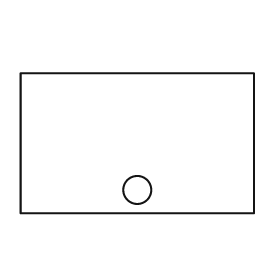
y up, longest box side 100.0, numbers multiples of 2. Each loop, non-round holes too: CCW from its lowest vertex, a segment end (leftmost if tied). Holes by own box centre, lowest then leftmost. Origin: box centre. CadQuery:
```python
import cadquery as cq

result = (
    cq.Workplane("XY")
    .moveTo(-50.0, -30.0)
    .lineTo(50.0, -30.0)
    .lineTo(50.0, 30.0)
    .lineTo(-50.0, 30.0)
    .close()
    .moveTo(0.0, -20.0)
    .circle(6.0)
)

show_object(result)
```